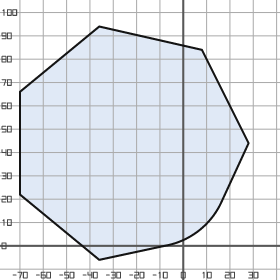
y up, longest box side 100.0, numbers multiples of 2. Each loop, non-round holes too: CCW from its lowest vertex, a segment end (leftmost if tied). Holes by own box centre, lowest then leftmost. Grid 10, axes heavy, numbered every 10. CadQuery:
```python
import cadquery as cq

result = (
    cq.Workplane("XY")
    .moveTo(-36.0, -6.0)
    .lineTo(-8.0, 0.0)
    .threePointArc((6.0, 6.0), (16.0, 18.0))
    .lineTo(28.0, 44.0)
    .lineTo(8.0, 84.0)
    .lineTo(-36.0, 94.0)
    .lineTo(-70.0, 66.0)
    .lineTo(-70.0, 22.0)
    .close()
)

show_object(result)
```